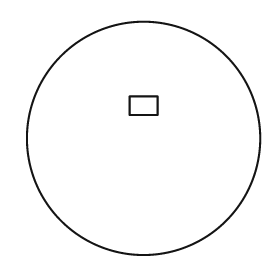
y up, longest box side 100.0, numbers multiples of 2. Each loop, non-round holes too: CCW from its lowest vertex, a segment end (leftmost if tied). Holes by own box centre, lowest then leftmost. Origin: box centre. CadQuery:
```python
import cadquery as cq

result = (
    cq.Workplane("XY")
    .moveTo(0.0, 0.0)
    .circle(50.0)
    .moveTo(-6.0, 10.0)
    .lineTo(6.0, 10.0)
    .lineTo(6.0, 18.0)
    .lineTo(-6.0, 18.0)
    .close()
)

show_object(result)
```